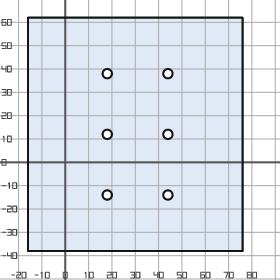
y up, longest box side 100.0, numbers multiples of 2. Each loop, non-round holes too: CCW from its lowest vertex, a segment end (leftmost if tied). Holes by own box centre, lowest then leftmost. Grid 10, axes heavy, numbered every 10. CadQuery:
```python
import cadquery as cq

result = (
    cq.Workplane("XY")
    .moveTo(-16.0, -38.0)
    .lineTo(76.0, -38.0)
    .lineTo(76.0, 62.0)
    .lineTo(-16.0, 62.0)
    .close()
    .moveTo(18.0, -14.0)
    .circle(2.0)
    .moveTo(44.0, -14.0)
    .circle(2.0)
    .moveTo(18.0, 12.0)
    .circle(2.0)
    .moveTo(44.0, 12.0)
    .circle(2.0)
    .moveTo(18.0, 38.0)
    .circle(2.0)
    .moveTo(44.0, 38.0)
    .circle(2.0)
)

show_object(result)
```